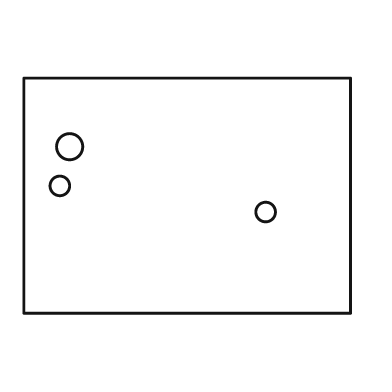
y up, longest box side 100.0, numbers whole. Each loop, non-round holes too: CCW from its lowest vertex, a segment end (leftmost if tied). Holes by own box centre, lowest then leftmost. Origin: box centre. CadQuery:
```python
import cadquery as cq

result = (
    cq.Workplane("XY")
    .moveTo(-50.0, -36.0)
    .lineTo(50.0, -36.0)
    .lineTo(50.0, 36.0)
    .lineTo(-50.0, 36.0)
    .close()
    .moveTo(24.0, -5.0)
    .circle(3.0)
    .moveTo(-39.0, 3.0)
    .circle(3.0)
    .moveTo(-36.0, 15.0)
    .circle(4.0)
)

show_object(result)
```